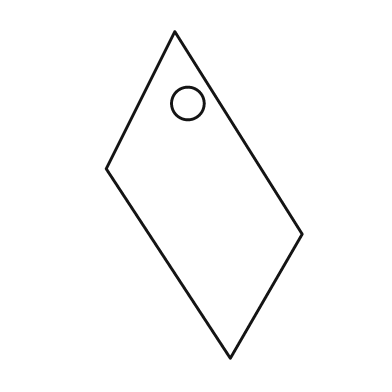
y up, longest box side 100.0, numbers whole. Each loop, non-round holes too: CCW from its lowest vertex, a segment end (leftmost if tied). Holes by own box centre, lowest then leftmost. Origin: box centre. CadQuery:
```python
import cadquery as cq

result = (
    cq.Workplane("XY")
    .moveTo(8.0, -50.0)
    .lineTo(30.0, -12.0)
    .lineTo(-9.0, 50.0)
    .lineTo(-30.0, 8.0)
    .close()
    .moveTo(-5.0, 28.0)
    .circle(5.0)
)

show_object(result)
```